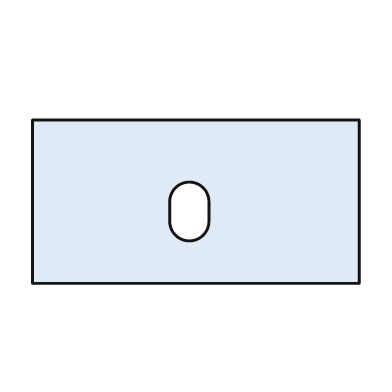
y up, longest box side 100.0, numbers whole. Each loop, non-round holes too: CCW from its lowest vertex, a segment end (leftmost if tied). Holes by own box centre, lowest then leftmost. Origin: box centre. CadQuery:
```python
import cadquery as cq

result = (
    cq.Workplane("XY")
    .moveTo(-50.0, -25.0)
    .lineTo(50.0, -25.0)
    .lineTo(50.0, 25.0)
    .lineTo(-50.0, 25.0)
    .close()
    .moveTo(-8.0, -6.0)
    .threePointArc((-2.0, -12.0), (4.0, -6.0))
    .lineTo(4.0, 0.0)
    .threePointArc((-2.0, 6.0), (-8.0, 0.0))
    .close()
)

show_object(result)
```